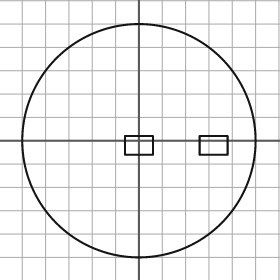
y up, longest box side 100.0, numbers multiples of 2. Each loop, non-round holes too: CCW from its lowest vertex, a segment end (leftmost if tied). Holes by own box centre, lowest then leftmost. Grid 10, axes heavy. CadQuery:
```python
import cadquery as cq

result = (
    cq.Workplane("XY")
    .moveTo(0.0, 0.0)
    .circle(50.0)
    .moveTo(-6.0, -6.0)
    .lineTo(6.0, -6.0)
    .lineTo(6.0, 2.0)
    .lineTo(-6.0, 2.0)
    .close()
    .moveTo(26.0, -6.0)
    .lineTo(38.0, -6.0)
    .lineTo(38.0, 2.0)
    .lineTo(26.0, 2.0)
    .close()
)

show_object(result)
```